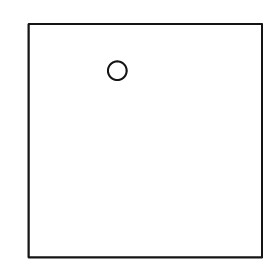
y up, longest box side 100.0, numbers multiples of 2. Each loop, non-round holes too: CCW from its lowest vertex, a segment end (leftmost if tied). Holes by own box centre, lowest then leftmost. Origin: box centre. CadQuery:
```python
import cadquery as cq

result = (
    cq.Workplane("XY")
    .moveTo(-50.0, -50.0)
    .lineTo(50.0, -50.0)
    .lineTo(50.0, 50.0)
    .lineTo(-50.0, 50.0)
    .close()
    .moveTo(-12.0, 30.0)
    .circle(4.0)
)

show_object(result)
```